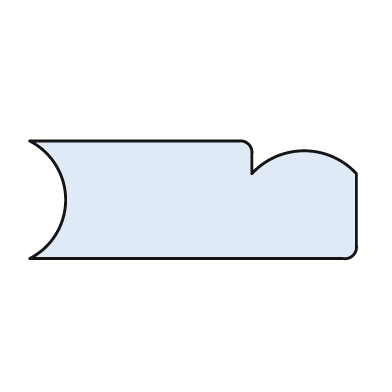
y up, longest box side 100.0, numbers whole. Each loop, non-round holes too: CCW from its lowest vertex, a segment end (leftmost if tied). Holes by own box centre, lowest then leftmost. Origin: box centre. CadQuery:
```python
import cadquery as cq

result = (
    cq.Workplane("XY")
    .moveTo(-50.0, -18.0)
    .lineTo(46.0, -18.0)
    .threePointArc((49.0, -17.0), (50.0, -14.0))
    .lineTo(50.0, 8.0)
    .threePointArc((34.0, 15.0), (18.0, 8.0))
    .lineTo(18.0, 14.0)
    .threePointArc((17.0, 17.0), (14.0, 18.0))
    .lineTo(-50.0, 18.0)
    .threePointArc((-39.0, 0.0), (-50.0, -18.0))
    .close()
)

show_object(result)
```